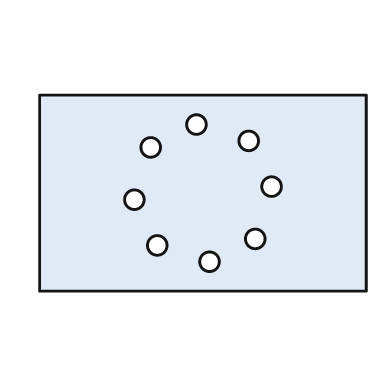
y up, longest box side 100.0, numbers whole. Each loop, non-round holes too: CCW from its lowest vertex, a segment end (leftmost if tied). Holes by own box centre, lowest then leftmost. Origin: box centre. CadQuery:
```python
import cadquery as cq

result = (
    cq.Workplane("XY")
    .moveTo(-50.0, -30.0)
    .lineTo(50.0, -30.0)
    .lineTo(50.0, 30.0)
    .lineTo(-50.0, 30.0)
    .close()
    .moveTo(2.0, -21.0)
    .circle(3.0)
    .moveTo(-14.0, -16.0)
    .circle(3.0)
    .moveTo(16.0, -14.0)
    .circle(3.0)
    .moveTo(-21.0, -2.0)
    .circle(3.0)
    .moveTo(21.0, 2.0)
    .circle(3.0)
    .moveTo(-16.0, 14.0)
    .circle(3.0)
    .moveTo(14.0, 16.0)
    .circle(3.0)
    .moveTo(-2.0, 21.0)
    .circle(3.0)
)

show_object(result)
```